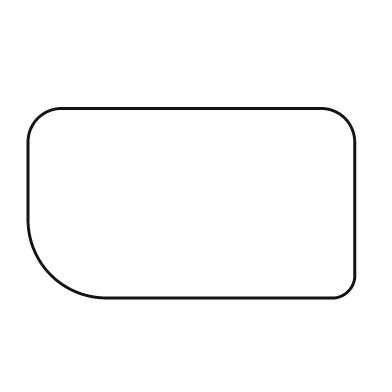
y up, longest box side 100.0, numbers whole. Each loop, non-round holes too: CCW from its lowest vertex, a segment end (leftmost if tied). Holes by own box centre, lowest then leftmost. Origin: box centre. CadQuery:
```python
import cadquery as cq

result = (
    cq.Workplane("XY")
    .moveTo(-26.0, -29.0)
    .lineTo(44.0, -29.0)
    .threePointArc((48.0, -27.0), (50.0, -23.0))
    .lineTo(50.0, 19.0)
    .threePointArc((47.0, 26.0), (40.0, 29.0))
    .lineTo(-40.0, 29.0)
    .threePointArc((-47.0, 26.0), (-50.0, 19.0))
    .lineTo(-50.0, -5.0)
    .threePointArc((-43.0, -22.0), (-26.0, -29.0))
    .close()
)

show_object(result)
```